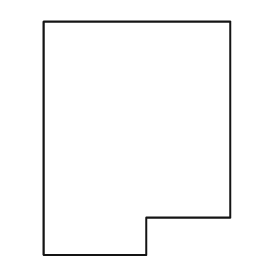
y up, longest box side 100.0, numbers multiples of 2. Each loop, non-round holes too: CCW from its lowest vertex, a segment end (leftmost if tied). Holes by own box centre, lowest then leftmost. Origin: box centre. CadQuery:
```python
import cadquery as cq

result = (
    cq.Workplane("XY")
    .moveTo(-40.0, -50.0)
    .lineTo(4.0, -50.0)
    .lineTo(4.0, -34.0)
    .lineTo(40.0, -34.0)
    .lineTo(40.0, 50.0)
    .lineTo(-40.0, 50.0)
    .close()
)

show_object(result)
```